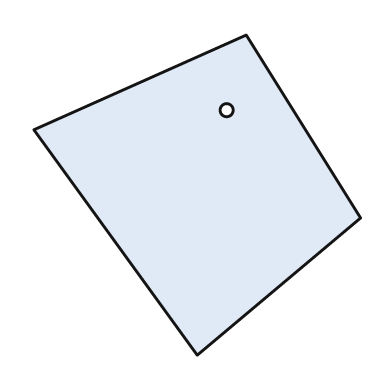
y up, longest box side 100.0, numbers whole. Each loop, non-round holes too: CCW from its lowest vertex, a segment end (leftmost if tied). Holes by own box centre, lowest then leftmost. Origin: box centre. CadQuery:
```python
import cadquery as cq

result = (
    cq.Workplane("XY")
    .moveTo(0.0, -49.0)
    .lineTo(50.0, -7.0)
    .lineTo(15.0, 49.0)
    .lineTo(-50.0, 20.0)
    .close()
    .moveTo(9.0, 26.0)
    .circle(2.0)
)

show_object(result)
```